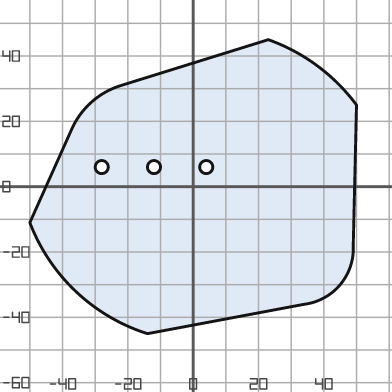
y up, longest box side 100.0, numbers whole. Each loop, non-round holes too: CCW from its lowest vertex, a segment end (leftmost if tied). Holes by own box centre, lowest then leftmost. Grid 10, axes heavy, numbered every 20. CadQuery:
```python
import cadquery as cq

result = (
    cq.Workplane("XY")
    .moveTo(-14.0, -45.0)
    .lineTo(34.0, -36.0)
    .threePointArc((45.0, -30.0), (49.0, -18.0))
    .lineTo(50.0, 25.0)
    .threePointArc((38.0, 37.0), (23.0, 45.0))
    .lineTo(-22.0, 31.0)
    .threePointArc((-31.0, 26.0), (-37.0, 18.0))
    .lineTo(-50.0, -11.0)
    .threePointArc((-36.0, -32.0), (-14.0, -45.0))
    .close()
    .moveTo(-28.0, 6.0)
    .circle(2.0)
    .moveTo(-12.0, 6.0)
    .circle(2.0)
    .moveTo(4.0, 6.0)
    .circle(2.0)
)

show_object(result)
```